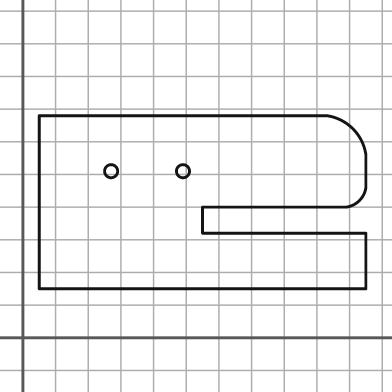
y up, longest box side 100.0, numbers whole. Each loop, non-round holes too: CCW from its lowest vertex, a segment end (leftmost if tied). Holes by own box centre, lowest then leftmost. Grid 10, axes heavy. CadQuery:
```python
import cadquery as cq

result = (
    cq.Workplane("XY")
    .moveTo(5.0, 15.0)
    .lineTo(105.0, 15.0)
    .lineTo(105.0, 32.0)
    .lineTo(55.0, 32.0)
    .lineTo(55.0, 40.0)
    .lineTo(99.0, 40.0)
    .threePointArc((103.0, 42.0), (105.0, 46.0))
    .lineTo(105.0, 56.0)
    .threePointArc((101.0, 64.0), (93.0, 68.0))
    .lineTo(5.0, 68.0)
    .close()
    .moveTo(27.0, 51.0)
    .circle(2.0)
    .moveTo(49.0, 51.0)
    .circle(2.0)
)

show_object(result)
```